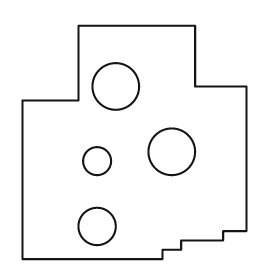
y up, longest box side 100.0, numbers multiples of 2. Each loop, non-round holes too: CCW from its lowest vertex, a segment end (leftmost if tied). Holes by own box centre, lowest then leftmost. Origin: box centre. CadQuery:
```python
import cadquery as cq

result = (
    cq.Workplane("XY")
    .moveTo(-48.0, -50.0)
    .lineTo(12.0, -50.0)
    .lineTo(12.0, -46.0)
    .lineTo(20.0, -46.0)
    .lineTo(20.0, -42.0)
    .lineTo(38.0, -42.0)
    .lineTo(38.0, -38.0)
    .lineTo(48.0, -38.0)
    .lineTo(48.0, 24.0)
    .lineTo(26.0, 24.0)
    .lineTo(26.0, 50.0)
    .lineTo(-24.0, 50.0)
    .lineTo(-24.0, 18.0)
    .lineTo(-48.0, 18.0)
    .close()
    .moveTo(-16.0, -36.0)
    .circle(8.0)
    .moveTo(-16.0, -8.0)
    .circle(6.0)
    .moveTo(16.0, -4.0)
    .circle(10.0)
    .moveTo(-8.0, 24.0)
    .circle(10.0)
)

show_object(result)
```